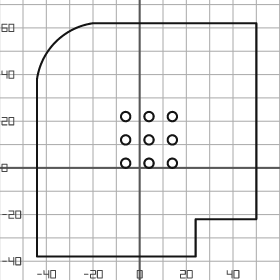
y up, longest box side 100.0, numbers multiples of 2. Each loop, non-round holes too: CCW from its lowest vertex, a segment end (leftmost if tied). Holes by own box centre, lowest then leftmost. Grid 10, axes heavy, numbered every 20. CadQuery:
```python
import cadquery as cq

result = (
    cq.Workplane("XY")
    .moveTo(-44.0, -38.0)
    .lineTo(24.0, -38.0)
    .lineTo(24.0, -22.0)
    .lineTo(50.0, -22.0)
    .lineTo(50.0, 62.0)
    .lineTo(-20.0, 62.0)
    .threePointArc((-36.0, 54.0), (-44.0, 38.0))
    .close()
    .moveTo(-6.0, 2.0)
    .circle(2.0)
    .moveTo(4.0, 2.0)
    .circle(2.0)
    .moveTo(14.0, 2.0)
    .circle(2.0)
    .moveTo(-6.0, 12.0)
    .circle(2.0)
    .moveTo(4.0, 12.0)
    .circle(2.0)
    .moveTo(14.0, 12.0)
    .circle(2.0)
    .moveTo(-6.0, 22.0)
    .circle(2.0)
    .moveTo(4.0, 22.0)
    .circle(2.0)
    .moveTo(14.0, 22.0)
    .circle(2.0)
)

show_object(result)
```